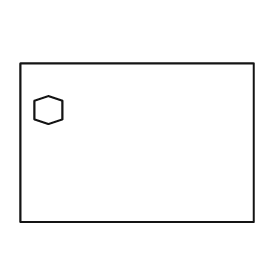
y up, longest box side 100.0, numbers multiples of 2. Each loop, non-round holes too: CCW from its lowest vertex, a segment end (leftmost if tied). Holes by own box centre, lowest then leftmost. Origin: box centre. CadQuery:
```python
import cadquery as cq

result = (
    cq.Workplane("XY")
    .moveTo(-50.0, -34.0)
    .lineTo(50.0, -34.0)
    .lineTo(50.0, 34.0)
    .lineTo(-50.0, 34.0)
    .close()
    .moveTo(-38.0, 8.0)
    .lineTo(-32.0, 10.0)
    .lineTo(-32.0, 18.0)
    .lineTo(-38.0, 20.0)
    .lineTo(-44.0, 18.0)
    .lineTo(-44.0, 10.0)
    .close()
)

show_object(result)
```